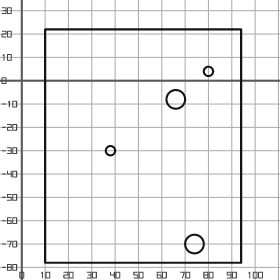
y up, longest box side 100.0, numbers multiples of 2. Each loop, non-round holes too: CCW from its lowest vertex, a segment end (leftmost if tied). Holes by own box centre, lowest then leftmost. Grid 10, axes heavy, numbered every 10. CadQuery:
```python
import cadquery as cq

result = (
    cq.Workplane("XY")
    .moveTo(10.0, -78.0)
    .lineTo(94.0, -78.0)
    .lineTo(94.0, 22.0)
    .lineTo(10.0, 22.0)
    .close()
    .moveTo(74.0, -70.0)
    .circle(4.0)
    .moveTo(38.0, -30.0)
    .circle(2.0)
    .moveTo(66.0, -8.0)
    .circle(4.0)
    .moveTo(80.0, 4.0)
    .circle(2.0)
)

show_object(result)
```